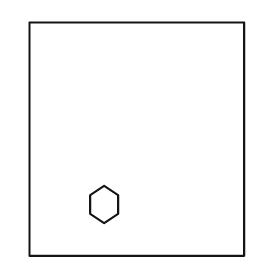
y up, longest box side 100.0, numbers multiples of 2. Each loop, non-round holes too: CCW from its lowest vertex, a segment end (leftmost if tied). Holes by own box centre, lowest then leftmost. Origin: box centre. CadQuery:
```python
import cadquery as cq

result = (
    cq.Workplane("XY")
    .moveTo(-46.0, -50.0)
    .lineTo(46.0, -50.0)
    .lineTo(46.0, 50.0)
    .lineTo(-46.0, 50.0)
    .close()
    .moveTo(-14.0, -36.0)
    .lineTo(-8.0, -32.0)
    .lineTo(-8.0, -24.0)
    .lineTo(-14.0, -20.0)
    .lineTo(-20.0, -24.0)
    .lineTo(-20.0, -32.0)
    .close()
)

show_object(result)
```